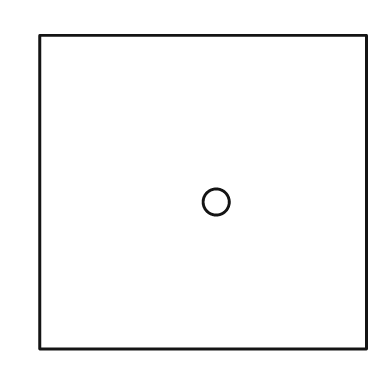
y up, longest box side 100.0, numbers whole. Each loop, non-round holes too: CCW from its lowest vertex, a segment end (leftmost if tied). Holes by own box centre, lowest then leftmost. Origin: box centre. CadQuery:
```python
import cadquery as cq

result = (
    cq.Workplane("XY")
    .moveTo(-50.0, -48.0)
    .lineTo(50.0, -48.0)
    .lineTo(50.0, 48.0)
    .lineTo(-50.0, 48.0)
    .close()
    .moveTo(4.0, -3.0)
    .circle(4.0)
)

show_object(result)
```